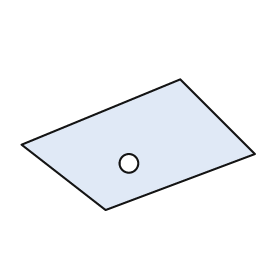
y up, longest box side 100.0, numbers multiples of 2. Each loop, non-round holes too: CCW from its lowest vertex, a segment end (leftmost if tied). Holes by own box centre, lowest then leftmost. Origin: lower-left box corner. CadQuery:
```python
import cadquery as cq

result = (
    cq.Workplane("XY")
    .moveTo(36.0, 0.0)
    .lineTo(100.0, 24.0)
    .lineTo(68.0, 56.0)
    .lineTo(0.0, 28.0)
    .close()
    .moveTo(46.0, 20.0)
    .circle(4.0)
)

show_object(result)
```